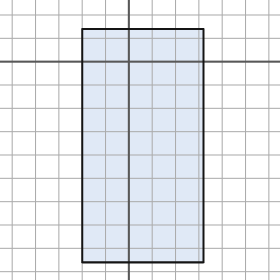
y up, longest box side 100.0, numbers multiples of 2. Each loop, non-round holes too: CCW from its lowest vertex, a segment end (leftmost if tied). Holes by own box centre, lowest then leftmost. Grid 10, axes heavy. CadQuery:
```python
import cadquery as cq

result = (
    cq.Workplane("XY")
    .moveTo(-20.0, -86.0)
    .lineTo(32.0, -86.0)
    .lineTo(32.0, 14.0)
    .lineTo(-20.0, 14.0)
    .close()
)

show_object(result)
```